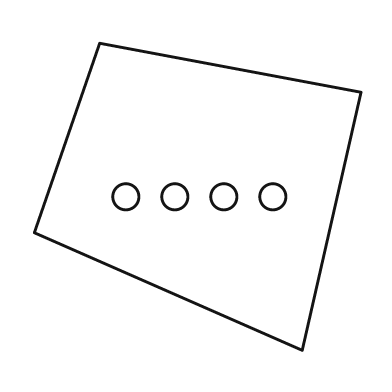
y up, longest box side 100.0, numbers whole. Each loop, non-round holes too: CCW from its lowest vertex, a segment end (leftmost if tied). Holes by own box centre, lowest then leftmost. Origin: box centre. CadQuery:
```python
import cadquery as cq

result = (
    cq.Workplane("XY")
    .moveTo(32.0, -47.0)
    .lineTo(50.0, 32.0)
    .lineTo(-30.0, 47.0)
    .lineTo(-50.0, -11.0)
    .close()
    .moveTo(-22.0, 0.0)
    .circle(4.0)
    .moveTo(-7.0, 0.0)
    .circle(4.0)
    .moveTo(8.0, 0.0)
    .circle(4.0)
    .moveTo(23.0, 0.0)
    .circle(4.0)
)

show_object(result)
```